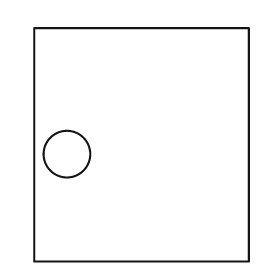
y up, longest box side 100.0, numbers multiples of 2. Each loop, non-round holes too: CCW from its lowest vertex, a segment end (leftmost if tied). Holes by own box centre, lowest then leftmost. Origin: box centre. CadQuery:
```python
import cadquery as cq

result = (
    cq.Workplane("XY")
    .moveTo(-46.0, -50.0)
    .lineTo(46.0, -50.0)
    .lineTo(46.0, 50.0)
    .lineTo(-46.0, 50.0)
    .close()
    .moveTo(-32.0, -4.0)
    .circle(10.0)
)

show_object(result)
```